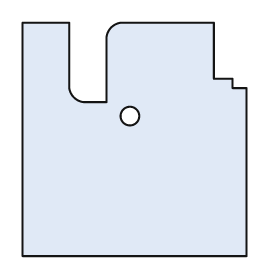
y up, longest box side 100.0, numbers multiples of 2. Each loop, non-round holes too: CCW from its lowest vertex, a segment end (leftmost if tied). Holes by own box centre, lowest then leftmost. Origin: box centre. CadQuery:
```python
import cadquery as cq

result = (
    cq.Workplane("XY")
    .moveTo(-48.0, -50.0)
    .lineTo(48.0, -50.0)
    .lineTo(48.0, 22.0)
    .lineTo(42.0, 22.0)
    .lineTo(42.0, 26.0)
    .lineTo(34.0, 26.0)
    .lineTo(34.0, 50.0)
    .lineTo(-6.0, 50.0)
    .threePointArc((-10.0, 48.0), (-12.0, 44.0))
    .lineTo(-12.0, 16.0)
    .lineTo(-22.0, 16.0)
    .threePointArc((-26.0, 18.0), (-28.0, 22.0))
    .lineTo(-28.0, 50.0)
    .lineTo(-48.0, 50.0)
    .close()
    .moveTo(-2.0, 10.0)
    .circle(4.0)
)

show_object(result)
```